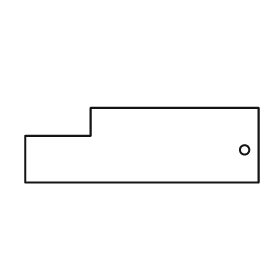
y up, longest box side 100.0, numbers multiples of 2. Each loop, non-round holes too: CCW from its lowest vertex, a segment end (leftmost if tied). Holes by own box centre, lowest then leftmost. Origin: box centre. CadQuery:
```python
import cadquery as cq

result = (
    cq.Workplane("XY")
    .moveTo(-50.0, -16.0)
    .lineTo(50.0, -16.0)
    .lineTo(50.0, 16.0)
    .lineTo(-22.0, 16.0)
    .lineTo(-22.0, 4.0)
    .lineTo(-50.0, 4.0)
    .close()
    .moveTo(44.0, -2.0)
    .circle(2.0)
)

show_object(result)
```